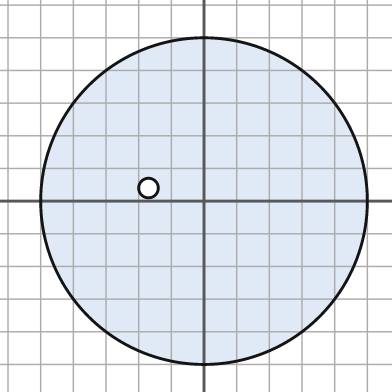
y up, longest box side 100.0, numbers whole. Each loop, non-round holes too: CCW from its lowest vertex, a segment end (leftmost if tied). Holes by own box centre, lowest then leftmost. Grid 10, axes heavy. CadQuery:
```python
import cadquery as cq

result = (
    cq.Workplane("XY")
    .moveTo(0.0, 0.0)
    .circle(50.0)
    .moveTo(-17.0, 4.0)
    .circle(3.0)
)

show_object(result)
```